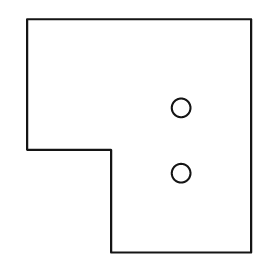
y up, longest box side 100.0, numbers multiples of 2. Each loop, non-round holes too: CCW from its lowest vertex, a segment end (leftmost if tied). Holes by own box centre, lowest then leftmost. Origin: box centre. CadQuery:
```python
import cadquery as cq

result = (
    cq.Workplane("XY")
    .moveTo(-12.0, -50.0)
    .lineTo(48.0, -50.0)
    .lineTo(48.0, 50.0)
    .lineTo(-48.0, 50.0)
    .lineTo(-48.0, -6.0)
    .lineTo(-12.0, -6.0)
    .close()
    .moveTo(18.0, -16.0)
    .circle(4.0)
    .moveTo(18.0, 12.0)
    .circle(4.0)
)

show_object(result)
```